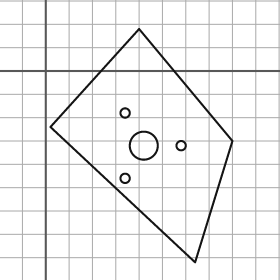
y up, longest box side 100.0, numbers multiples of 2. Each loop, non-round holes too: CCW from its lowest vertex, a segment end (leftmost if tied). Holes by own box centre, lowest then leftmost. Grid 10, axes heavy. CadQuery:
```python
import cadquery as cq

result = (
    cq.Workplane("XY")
    .moveTo(64.0, -82.0)
    .lineTo(80.0, -30.0)
    .lineTo(40.0, 18.0)
    .lineTo(2.0, -24.0)
    .close()
    .moveTo(34.0, -46.0)
    .circle(2.0)
    .moveTo(42.0, -32.0)
    .circle(6.0)
    .moveTo(58.0, -32.0)
    .circle(2.0)
    .moveTo(34.0, -18.0)
    .circle(2.0)
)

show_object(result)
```